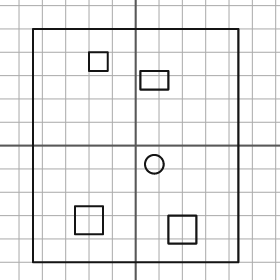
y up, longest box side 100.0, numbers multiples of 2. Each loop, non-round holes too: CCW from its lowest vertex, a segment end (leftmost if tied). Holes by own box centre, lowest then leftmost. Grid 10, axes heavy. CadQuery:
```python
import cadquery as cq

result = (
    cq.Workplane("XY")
    .moveTo(-44.0, -50.0)
    .lineTo(44.0, -50.0)
    .lineTo(44.0, 50.0)
    .lineTo(-44.0, 50.0)
    .close()
    .moveTo(14.0, -42.0)
    .lineTo(26.0, -42.0)
    .lineTo(26.0, -30.0)
    .lineTo(14.0, -30.0)
    .close()
    .moveTo(-26.0, -38.0)
    .lineTo(-14.0, -38.0)
    .lineTo(-14.0, -26.0)
    .lineTo(-26.0, -26.0)
    .close()
    .moveTo(8.0, -8.0)
    .circle(4.0)
    .moveTo(2.0, 24.0)
    .lineTo(14.0, 24.0)
    .lineTo(14.0, 32.0)
    .lineTo(2.0, 32.0)
    .close()
    .moveTo(-20.0, 32.0)
    .lineTo(-12.0, 32.0)
    .lineTo(-12.0, 40.0)
    .lineTo(-20.0, 40.0)
    .close()
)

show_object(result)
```